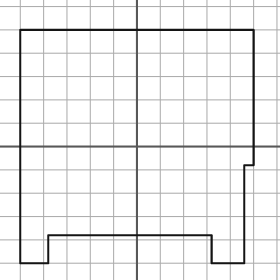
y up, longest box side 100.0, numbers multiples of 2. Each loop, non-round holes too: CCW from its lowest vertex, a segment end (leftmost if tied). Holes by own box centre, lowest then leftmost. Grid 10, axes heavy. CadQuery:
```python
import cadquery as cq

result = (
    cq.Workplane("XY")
    .moveTo(-50.0, -50.0)
    .lineTo(-38.0, -50.0)
    .lineTo(-38.0, -38.0)
    .lineTo(32.0, -38.0)
    .lineTo(32.0, -50.0)
    .lineTo(46.0, -50.0)
    .lineTo(46.0, -8.0)
    .lineTo(50.0, -8.0)
    .lineTo(50.0, 50.0)
    .lineTo(-50.0, 50.0)
    .close()
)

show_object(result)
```